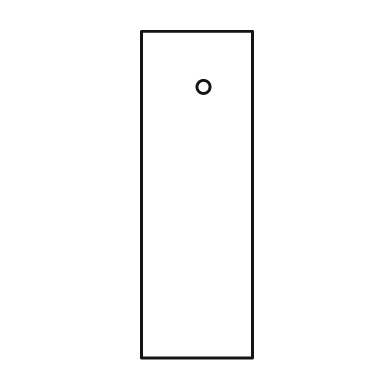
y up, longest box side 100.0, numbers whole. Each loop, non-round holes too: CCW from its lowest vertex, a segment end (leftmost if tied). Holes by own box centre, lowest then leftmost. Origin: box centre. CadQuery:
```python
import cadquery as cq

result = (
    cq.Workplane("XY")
    .moveTo(-17.0, -50.0)
    .lineTo(17.0, -50.0)
    .lineTo(17.0, 50.0)
    .lineTo(-17.0, 50.0)
    .close()
    .moveTo(2.0, 33.0)
    .circle(2.0)
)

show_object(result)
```